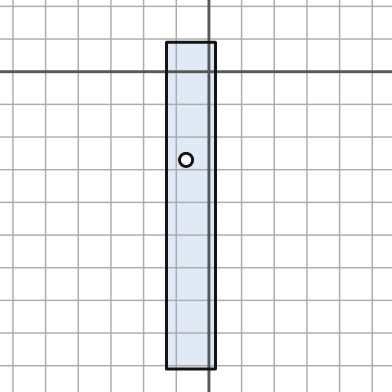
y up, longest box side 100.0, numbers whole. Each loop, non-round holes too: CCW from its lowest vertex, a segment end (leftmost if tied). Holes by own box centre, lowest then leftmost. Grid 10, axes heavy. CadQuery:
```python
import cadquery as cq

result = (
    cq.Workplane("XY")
    .moveTo(-13.0, -91.0)
    .lineTo(2.0, -91.0)
    .lineTo(2.0, 9.0)
    .lineTo(-13.0, 9.0)
    .close()
    .moveTo(-7.0, -27.0)
    .circle(2.0)
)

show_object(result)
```